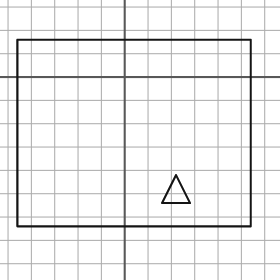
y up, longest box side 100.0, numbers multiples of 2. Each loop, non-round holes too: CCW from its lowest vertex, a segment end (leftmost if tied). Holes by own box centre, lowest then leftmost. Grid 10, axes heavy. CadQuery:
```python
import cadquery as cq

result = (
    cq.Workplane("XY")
    .moveTo(-46.0, -64.0)
    .lineTo(54.0, -64.0)
    .lineTo(54.0, 16.0)
    .lineTo(-46.0, 16.0)
    .close()
    .moveTo(16.0, -54.0)
    .lineTo(28.0, -54.0)
    .lineTo(22.0, -42.0)
    .close()
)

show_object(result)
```